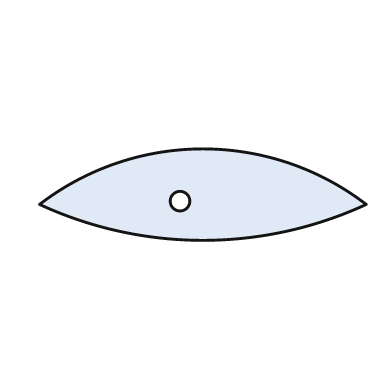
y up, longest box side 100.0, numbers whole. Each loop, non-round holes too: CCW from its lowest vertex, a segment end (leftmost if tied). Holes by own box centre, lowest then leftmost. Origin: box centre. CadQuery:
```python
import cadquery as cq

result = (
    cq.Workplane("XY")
    .moveTo(-50.0, -3.0)
    .threePointArc((0.0, -14.0), (50.0, -3.0))
    .threePointArc((0.0, 14.0), (-50.0, -3.0))
    .close()
    .moveTo(-7.0, -2.0)
    .circle(3.0)
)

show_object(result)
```